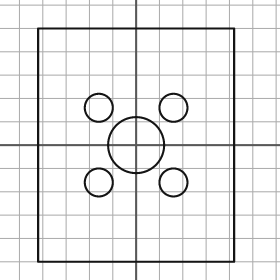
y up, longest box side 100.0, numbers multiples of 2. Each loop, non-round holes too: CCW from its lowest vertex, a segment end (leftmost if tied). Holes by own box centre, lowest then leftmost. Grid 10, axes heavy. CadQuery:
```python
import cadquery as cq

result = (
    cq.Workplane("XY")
    .moveTo(-42.0, -50.0)
    .lineTo(42.0, -50.0)
    .lineTo(42.0, 50.0)
    .lineTo(-42.0, 50.0)
    .close()
    .moveTo(-16.0, -16.0)
    .circle(6.0)
    .moveTo(16.0, -16.0)
    .circle(6.0)
    .moveTo(0.0, 0.0)
    .circle(12.0)
    .moveTo(-16.0, 16.0)
    .circle(6.0)
    .moveTo(16.0, 16.0)
    .circle(6.0)
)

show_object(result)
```